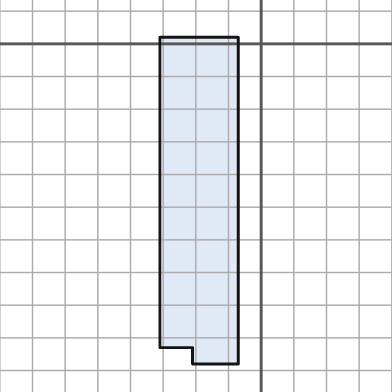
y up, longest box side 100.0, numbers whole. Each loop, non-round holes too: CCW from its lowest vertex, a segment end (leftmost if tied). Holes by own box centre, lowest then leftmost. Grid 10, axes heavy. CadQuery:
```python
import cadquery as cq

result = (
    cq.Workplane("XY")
    .moveTo(-21.0, -98.0)
    .lineTo(-7.0, -98.0)
    .lineTo(-7.0, 2.0)
    .lineTo(-31.0, 2.0)
    .lineTo(-31.0, -93.0)
    .lineTo(-21.0, -93.0)
    .close()
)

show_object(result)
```